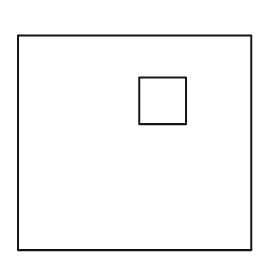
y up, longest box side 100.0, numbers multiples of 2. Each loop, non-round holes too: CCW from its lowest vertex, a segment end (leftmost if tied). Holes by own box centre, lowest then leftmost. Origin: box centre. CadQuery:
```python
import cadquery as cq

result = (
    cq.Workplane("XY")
    .moveTo(-50.0, -46.0)
    .lineTo(50.0, -46.0)
    .lineTo(50.0, 46.0)
    .lineTo(-50.0, 46.0)
    .close()
    .moveTo(2.0, 8.0)
    .lineTo(22.0, 8.0)
    .lineTo(22.0, 28.0)
    .lineTo(2.0, 28.0)
    .close()
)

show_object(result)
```